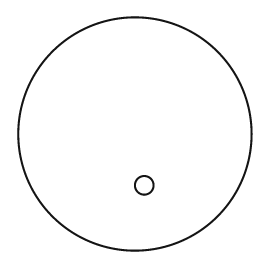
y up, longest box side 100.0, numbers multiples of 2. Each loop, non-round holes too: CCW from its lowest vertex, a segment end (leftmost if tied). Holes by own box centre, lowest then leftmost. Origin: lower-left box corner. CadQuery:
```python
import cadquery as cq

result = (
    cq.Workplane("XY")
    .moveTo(50.0, 50.0)
    .circle(50.0)
    .moveTo(54.0, 28.0)
    .circle(4.0)
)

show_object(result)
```